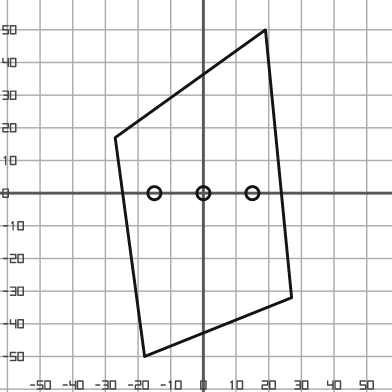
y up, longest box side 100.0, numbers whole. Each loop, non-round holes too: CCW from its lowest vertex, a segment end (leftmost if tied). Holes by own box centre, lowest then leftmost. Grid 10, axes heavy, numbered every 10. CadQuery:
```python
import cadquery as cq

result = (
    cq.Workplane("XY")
    .moveTo(-18.0, -50.0)
    .lineTo(27.0, -32.0)
    .lineTo(19.0, 50.0)
    .lineTo(-27.0, 17.0)
    .close()
    .moveTo(-15.0, 0.0)
    .circle(2.0)
    .moveTo(0.0, 0.0)
    .circle(2.0)
    .moveTo(15.0, 0.0)
    .circle(2.0)
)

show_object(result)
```